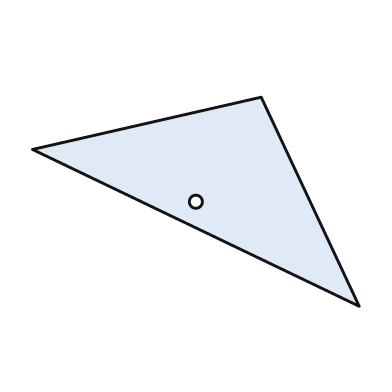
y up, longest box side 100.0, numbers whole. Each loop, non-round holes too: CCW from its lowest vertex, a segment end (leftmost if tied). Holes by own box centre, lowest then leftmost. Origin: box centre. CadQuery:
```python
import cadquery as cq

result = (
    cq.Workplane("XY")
    .moveTo(50.0, -32.0)
    .lineTo(20.0, 32.0)
    .lineTo(-50.0, 16.0)
    .close()
    .moveTo(0.0, 0.0)
    .circle(2.0)
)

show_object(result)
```